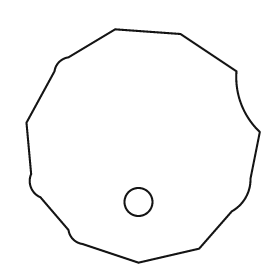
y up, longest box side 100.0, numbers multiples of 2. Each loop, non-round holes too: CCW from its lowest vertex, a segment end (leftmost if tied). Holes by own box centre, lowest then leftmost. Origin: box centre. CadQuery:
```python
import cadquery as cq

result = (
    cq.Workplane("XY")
    .moveTo(-2.0, -50.0)
    .lineTo(24.0, -44.0)
    .lineTo(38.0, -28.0)
    .threePointArc((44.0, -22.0), (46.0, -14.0))
    .lineTo(50.0, 6.0)
    .threePointArc((42.0, 18.0), (40.0, 32.0))
    .lineTo(16.0, 48.0)
    .lineTo(-12.0, 50.0)
    .lineTo(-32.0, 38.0)
    .threePointArc((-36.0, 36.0), (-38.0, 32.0))
    .lineTo(-50.0, 10.0)
    .lineTo(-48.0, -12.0)
    .threePointArc((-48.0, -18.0), (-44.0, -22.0))
    .lineTo(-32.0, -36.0)
    .threePointArc((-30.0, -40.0), (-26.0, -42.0))
    .close()
    .moveTo(-2.0, -24.0)
    .circle(6.0)
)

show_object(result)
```